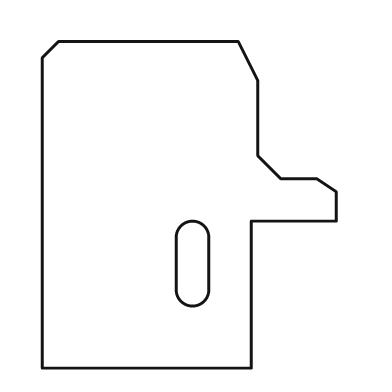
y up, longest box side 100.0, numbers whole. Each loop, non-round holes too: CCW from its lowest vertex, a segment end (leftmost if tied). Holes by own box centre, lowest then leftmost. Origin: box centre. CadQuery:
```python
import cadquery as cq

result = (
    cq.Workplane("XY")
    .moveTo(-45.0, -50.0)
    .lineTo(19.0, -50.0)
    .lineTo(19.0, -5.0)
    .lineTo(45.0, -5.0)
    .lineTo(45.0, 4.0)
    .lineTo(39.0, 8.0)
    .lineTo(28.0, 8.0)
    .lineTo(21.0, 15.0)
    .lineTo(21.0, 38.0)
    .lineTo(15.0, 50.0)
    .lineTo(-40.0, 50.0)
    .lineTo(-45.0, 45.0)
    .close()
    .moveTo(-4.0, -26.0)
    .threePointArc((1.0, -31.0), (6.0, -26.0))
    .lineTo(6.0, -10.0)
    .threePointArc((1.0, -5.0), (-4.0, -10.0))
    .close()
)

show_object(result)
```